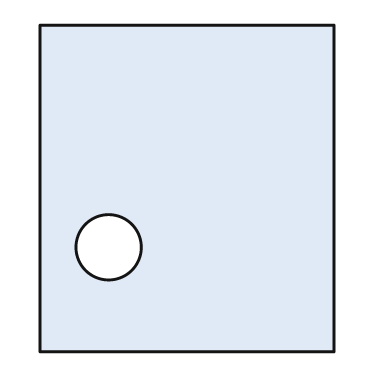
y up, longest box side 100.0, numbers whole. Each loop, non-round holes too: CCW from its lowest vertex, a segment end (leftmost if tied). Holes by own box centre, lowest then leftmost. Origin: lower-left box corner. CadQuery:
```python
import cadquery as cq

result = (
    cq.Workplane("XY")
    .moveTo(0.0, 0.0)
    .lineTo(90.0, 0.0)
    .lineTo(90.0, 100.0)
    .lineTo(0.0, 100.0)
    .close()
    .moveTo(21.0, 32.0)
    .circle(10.0)
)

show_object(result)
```